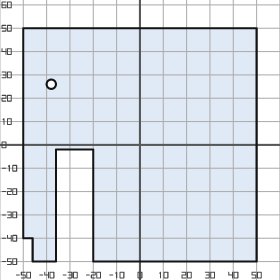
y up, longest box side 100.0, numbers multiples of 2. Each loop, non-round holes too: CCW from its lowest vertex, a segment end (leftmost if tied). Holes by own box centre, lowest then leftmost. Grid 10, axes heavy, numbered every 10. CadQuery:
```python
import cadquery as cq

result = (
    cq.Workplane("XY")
    .moveTo(-46.0, -50.0)
    .lineTo(-36.0, -50.0)
    .lineTo(-36.0, -2.0)
    .lineTo(-20.0, -2.0)
    .lineTo(-20.0, -50.0)
    .lineTo(50.0, -50.0)
    .lineTo(50.0, 50.0)
    .lineTo(-50.0, 50.0)
    .lineTo(-50.0, -40.0)
    .lineTo(-46.0, -40.0)
    .close()
    .moveTo(-38.0, 26.0)
    .circle(2.0)
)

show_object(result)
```